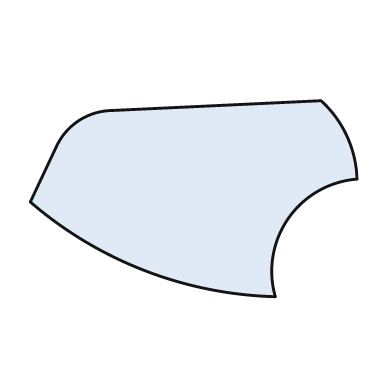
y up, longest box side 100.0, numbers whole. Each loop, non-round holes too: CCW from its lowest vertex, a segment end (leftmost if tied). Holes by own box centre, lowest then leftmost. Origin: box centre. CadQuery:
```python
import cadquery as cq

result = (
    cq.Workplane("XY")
    .moveTo(25.0, -30.0)
    .threePointArc((29.0, -6.0), (50.0, 6.0))
    .threePointArc((47.0, 19.0), (39.0, 30.0))
    .lineTo(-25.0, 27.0)
    .threePointArc((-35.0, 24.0), (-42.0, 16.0))
    .lineTo(-50.0, -1.0)
    .threePointArc((-15.0, -22.0), (25.0, -30.0))
    .close()
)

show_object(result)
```